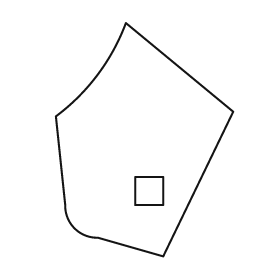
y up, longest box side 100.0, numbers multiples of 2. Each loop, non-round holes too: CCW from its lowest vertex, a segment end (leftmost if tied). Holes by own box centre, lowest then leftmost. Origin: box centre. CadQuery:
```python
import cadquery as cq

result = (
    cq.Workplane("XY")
    .moveTo(8.0, -50.0)
    .lineTo(38.0, 12.0)
    .lineTo(-8.0, 50.0)
    .threePointArc((-20.0, 28.0), (-38.0, 10.0))
    .lineTo(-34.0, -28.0)
    .threePointArc((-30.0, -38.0), (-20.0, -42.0))
    .close()
    .moveTo(-4.0, -28.0)
    .lineTo(8.0, -28.0)
    .lineTo(8.0, -16.0)
    .lineTo(-4.0, -16.0)
    .close()
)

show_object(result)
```